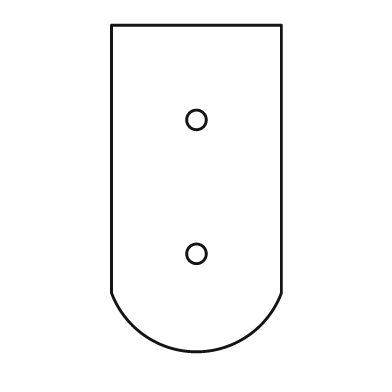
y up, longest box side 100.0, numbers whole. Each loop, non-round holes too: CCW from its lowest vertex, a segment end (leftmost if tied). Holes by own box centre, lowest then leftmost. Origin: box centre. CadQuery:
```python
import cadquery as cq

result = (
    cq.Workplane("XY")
    .moveTo(-26.0, -32.0)
    .threePointArc((0.0, -50.0), (26.0, -32.0))
    .lineTo(26.0, 50.0)
    .lineTo(-26.0, 50.0)
    .close()
    .moveTo(0.0, -20.0)
    .circle(3.0)
    .moveTo(0.0, 21.0)
    .circle(3.0)
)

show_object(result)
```